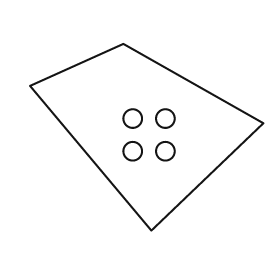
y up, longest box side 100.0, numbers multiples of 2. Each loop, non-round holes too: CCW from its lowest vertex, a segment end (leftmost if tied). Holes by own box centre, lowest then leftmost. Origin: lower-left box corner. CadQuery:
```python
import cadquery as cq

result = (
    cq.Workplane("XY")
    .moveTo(52.0, 0.0)
    .lineTo(100.0, 46.0)
    .lineTo(40.0, 80.0)
    .lineTo(0.0, 62.0)
    .close()
    .moveTo(44.0, 34.0)
    .circle(4.0)
    .moveTo(58.0, 34.0)
    .circle(4.0)
    .moveTo(44.0, 48.0)
    .circle(4.0)
    .moveTo(58.0, 48.0)
    .circle(4.0)
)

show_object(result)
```